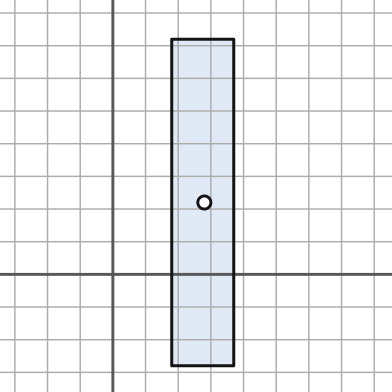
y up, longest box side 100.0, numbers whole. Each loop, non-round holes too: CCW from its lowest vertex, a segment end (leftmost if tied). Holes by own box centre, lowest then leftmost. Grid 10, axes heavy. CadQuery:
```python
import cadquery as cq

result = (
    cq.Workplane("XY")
    .moveTo(18.0, -28.0)
    .lineTo(37.0, -28.0)
    .lineTo(37.0, 72.0)
    .lineTo(18.0, 72.0)
    .close()
    .moveTo(28.0, 22.0)
    .circle(2.0)
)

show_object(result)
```